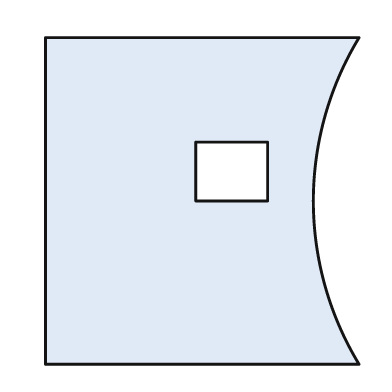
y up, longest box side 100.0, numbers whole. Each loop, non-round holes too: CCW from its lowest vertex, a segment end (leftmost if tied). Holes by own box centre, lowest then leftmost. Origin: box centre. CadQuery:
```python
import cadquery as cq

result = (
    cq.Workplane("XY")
    .moveTo(-48.0, -50.0)
    .lineTo(48.0, -50.0)
    .threePointArc((34.0, 0.0), (48.0, 50.0))
    .lineTo(-48.0, 50.0)
    .close()
    .moveTo(-2.0, 0.0)
    .lineTo(20.0, 0.0)
    .lineTo(20.0, 18.0)
    .lineTo(-2.0, 18.0)
    .close()
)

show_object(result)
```